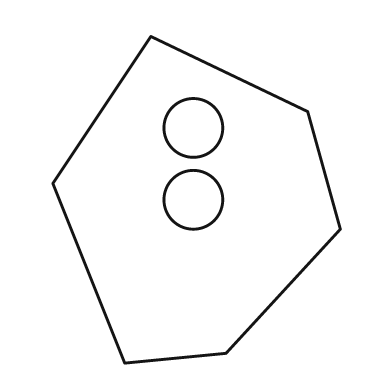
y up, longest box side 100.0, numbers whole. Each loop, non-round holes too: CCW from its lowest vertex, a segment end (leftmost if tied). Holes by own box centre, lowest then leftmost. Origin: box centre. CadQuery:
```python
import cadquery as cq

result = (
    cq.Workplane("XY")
    .moveTo(-22.0, -50.0)
    .lineTo(9.0, -47.0)
    .lineTo(44.0, -9.0)
    .lineTo(34.0, 27.0)
    .lineTo(-14.0, 50.0)
    .lineTo(-44.0, 5.0)
    .close()
    .moveTo(-1.0, 0.0)
    .circle(9.0)
    .moveTo(-1.0, 22.0)
    .circle(9.0)
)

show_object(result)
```